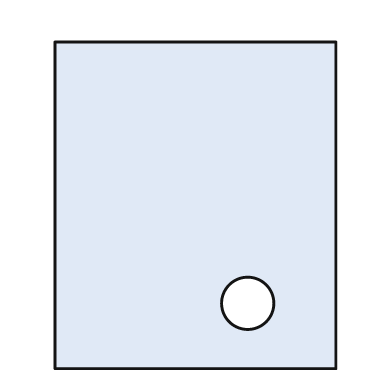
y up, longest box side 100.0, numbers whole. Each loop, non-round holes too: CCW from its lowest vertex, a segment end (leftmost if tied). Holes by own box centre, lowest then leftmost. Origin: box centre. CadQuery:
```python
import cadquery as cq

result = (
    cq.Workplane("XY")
    .moveTo(-43.0, -50.0)
    .lineTo(43.0, -50.0)
    .lineTo(43.0, 50.0)
    .lineTo(-43.0, 50.0)
    .close()
    .moveTo(16.0, -30.0)
    .circle(8.0)
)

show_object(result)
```